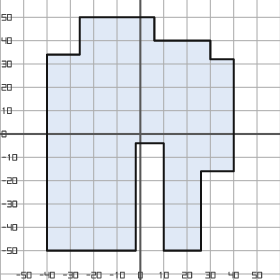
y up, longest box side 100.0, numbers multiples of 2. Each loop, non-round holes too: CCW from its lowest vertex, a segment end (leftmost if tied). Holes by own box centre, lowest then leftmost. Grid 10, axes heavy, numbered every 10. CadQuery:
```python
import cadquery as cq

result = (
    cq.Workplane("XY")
    .moveTo(-40.0, -50.0)
    .lineTo(-2.0, -50.0)
    .lineTo(-2.0, -4.0)
    .lineTo(10.0, -4.0)
    .lineTo(10.0, -50.0)
    .lineTo(26.0, -50.0)
    .lineTo(26.0, -16.0)
    .lineTo(40.0, -16.0)
    .lineTo(40.0, 32.0)
    .lineTo(30.0, 32.0)
    .lineTo(30.0, 40.0)
    .lineTo(6.0, 40.0)
    .lineTo(6.0, 50.0)
    .lineTo(-26.0, 50.0)
    .lineTo(-26.0, 34.0)
    .lineTo(-40.0, 34.0)
    .close()
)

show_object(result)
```